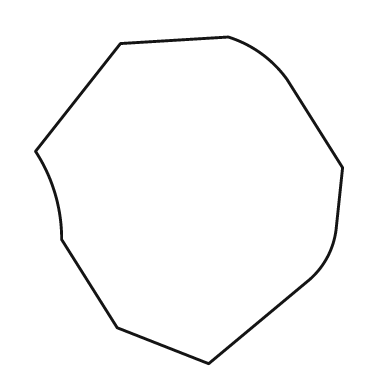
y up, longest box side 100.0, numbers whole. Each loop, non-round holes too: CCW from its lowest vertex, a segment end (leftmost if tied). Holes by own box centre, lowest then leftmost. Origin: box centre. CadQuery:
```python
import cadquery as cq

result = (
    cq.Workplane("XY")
    .moveTo(6.0, -50.0)
    .lineTo(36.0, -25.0)
    .threePointArc((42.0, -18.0), (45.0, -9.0))
    .lineTo(47.0, 10.0)
    .lineTo(30.0, 37.0)
    .threePointArc((22.0, 45.0), (12.0, 50.0))
    .lineTo(-21.0, 48.0)
    .lineTo(-47.0, 15.0)
    .threePointArc((-41.0, 2.0), (-39.0, -12.0))
    .lineTo(-22.0, -39.0)
    .close()
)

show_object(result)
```